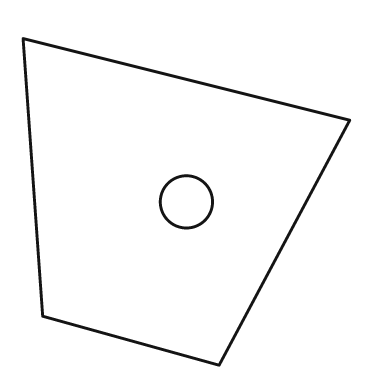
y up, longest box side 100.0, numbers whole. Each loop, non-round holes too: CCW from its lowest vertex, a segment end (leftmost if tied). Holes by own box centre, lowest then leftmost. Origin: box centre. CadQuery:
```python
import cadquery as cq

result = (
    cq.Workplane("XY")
    .moveTo(10.0, -50.0)
    .lineTo(50.0, 25.0)
    .lineTo(-50.0, 50.0)
    .lineTo(-44.0, -35.0)
    .close()
    .moveTo(0.0, 0.0)
    .circle(8.0)
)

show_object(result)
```